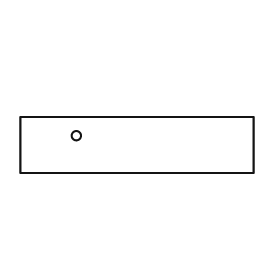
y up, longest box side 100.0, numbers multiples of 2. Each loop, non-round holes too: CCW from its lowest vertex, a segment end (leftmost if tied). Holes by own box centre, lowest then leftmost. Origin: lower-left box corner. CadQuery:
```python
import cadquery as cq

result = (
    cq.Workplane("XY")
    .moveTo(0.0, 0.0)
    .lineTo(100.0, 0.0)
    .lineTo(100.0, 24.0)
    .lineTo(0.0, 24.0)
    .close()
    .moveTo(24.0, 16.0)
    .circle(2.0)
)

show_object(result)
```